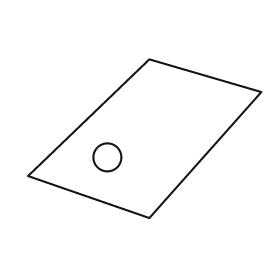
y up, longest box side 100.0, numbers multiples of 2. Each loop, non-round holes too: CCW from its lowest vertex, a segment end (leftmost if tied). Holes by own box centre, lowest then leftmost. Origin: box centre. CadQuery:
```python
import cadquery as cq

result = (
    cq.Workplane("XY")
    .moveTo(2.0, -34.0)
    .lineTo(50.0, 20.0)
    .lineTo(2.0, 34.0)
    .lineTo(-50.0, -16.0)
    .close()
    .moveTo(-16.0, -8.0)
    .circle(6.0)
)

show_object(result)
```